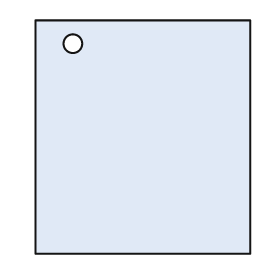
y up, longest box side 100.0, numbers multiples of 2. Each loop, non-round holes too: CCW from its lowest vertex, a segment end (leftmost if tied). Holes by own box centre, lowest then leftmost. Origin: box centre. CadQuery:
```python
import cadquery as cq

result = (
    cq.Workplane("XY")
    .moveTo(-46.0, -50.0)
    .lineTo(46.0, -50.0)
    .lineTo(46.0, 50.0)
    .lineTo(-46.0, 50.0)
    .close()
    .moveTo(-30.0, 40.0)
    .circle(4.0)
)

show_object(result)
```